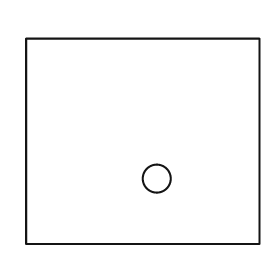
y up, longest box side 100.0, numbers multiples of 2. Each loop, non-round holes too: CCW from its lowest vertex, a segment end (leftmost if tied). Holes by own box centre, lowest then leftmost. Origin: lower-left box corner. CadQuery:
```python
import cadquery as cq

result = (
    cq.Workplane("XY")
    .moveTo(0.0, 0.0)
    .lineTo(100.0, 0.0)
    .lineTo(100.0, 88.0)
    .lineTo(0.0, 88.0)
    .close()
    .moveTo(56.0, 28.0)
    .circle(6.0)
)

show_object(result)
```